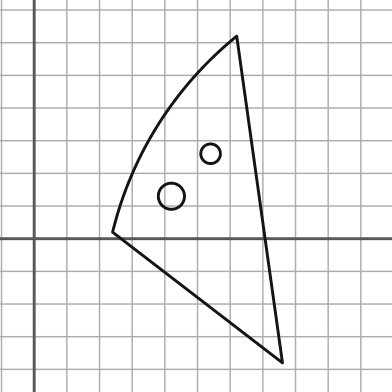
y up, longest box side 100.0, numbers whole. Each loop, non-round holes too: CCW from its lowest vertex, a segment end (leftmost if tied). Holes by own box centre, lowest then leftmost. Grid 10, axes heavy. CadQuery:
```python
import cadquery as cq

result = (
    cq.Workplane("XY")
    .moveTo(76.0, -38.0)
    .lineTo(62.0, 62.0)
    .threePointArc((38.0, 35.0), (24.0, 2.0))
    .close()
    .moveTo(42.0, 13.0)
    .circle(4.0)
    .moveTo(54.0, 26.0)
    .circle(3.0)
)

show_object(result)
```